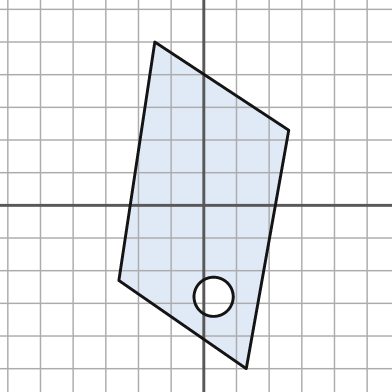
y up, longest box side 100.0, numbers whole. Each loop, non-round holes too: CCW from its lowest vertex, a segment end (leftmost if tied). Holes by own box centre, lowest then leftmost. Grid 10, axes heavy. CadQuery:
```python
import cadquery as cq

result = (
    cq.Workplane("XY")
    .moveTo(13.0, -50.0)
    .lineTo(26.0, 23.0)
    .lineTo(-15.0, 50.0)
    .lineTo(-26.0, -23.0)
    .close()
    .moveTo(3.0, -28.0)
    .circle(6.0)
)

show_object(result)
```